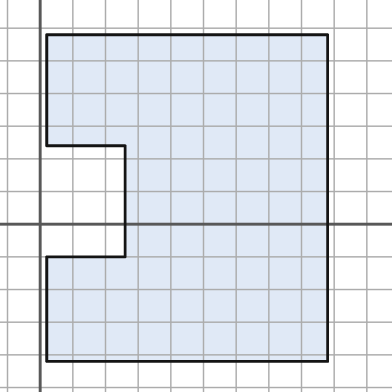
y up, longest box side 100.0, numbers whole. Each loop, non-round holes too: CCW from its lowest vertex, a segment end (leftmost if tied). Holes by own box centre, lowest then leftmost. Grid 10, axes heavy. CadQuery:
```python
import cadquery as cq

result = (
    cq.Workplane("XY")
    .moveTo(2.0, -42.0)
    .lineTo(88.0, -42.0)
    .lineTo(88.0, 58.0)
    .lineTo(2.0, 58.0)
    .lineTo(2.0, 24.0)
    .lineTo(26.0, 24.0)
    .lineTo(26.0, -10.0)
    .lineTo(2.0, -10.0)
    .close()
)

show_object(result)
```